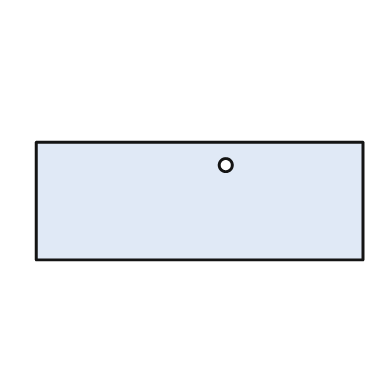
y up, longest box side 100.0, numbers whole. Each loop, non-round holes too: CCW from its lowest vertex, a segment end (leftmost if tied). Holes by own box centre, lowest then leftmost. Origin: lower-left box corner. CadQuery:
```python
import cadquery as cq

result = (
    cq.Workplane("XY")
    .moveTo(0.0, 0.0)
    .lineTo(100.0, 0.0)
    .lineTo(100.0, 36.0)
    .lineTo(0.0, 36.0)
    .close()
    .moveTo(58.0, 29.0)
    .circle(2.0)
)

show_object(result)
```